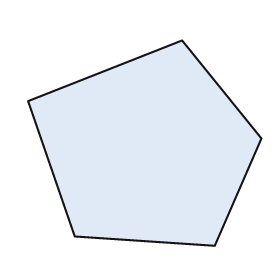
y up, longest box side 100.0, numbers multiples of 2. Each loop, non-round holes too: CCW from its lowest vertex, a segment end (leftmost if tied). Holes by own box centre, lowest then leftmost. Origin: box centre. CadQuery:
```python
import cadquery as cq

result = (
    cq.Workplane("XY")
    .moveTo(30.0, -44.0)
    .lineTo(50.0, 2.0)
    .lineTo(16.0, 44.0)
    .lineTo(-50.0, 18.0)
    .lineTo(-30.0, -40.0)
    .close()
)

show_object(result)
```